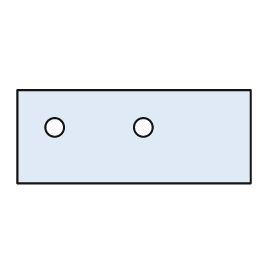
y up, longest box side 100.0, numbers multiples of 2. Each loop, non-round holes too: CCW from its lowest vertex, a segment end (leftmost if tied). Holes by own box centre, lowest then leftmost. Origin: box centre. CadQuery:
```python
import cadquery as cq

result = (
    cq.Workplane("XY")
    .moveTo(-50.0, -20.0)
    .lineTo(50.0, -20.0)
    .lineTo(50.0, 20.0)
    .lineTo(-50.0, 20.0)
    .close()
    .moveTo(-34.0, 4.0)
    .circle(4.0)
    .moveTo(4.0, 4.0)
    .circle(4.0)
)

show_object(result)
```